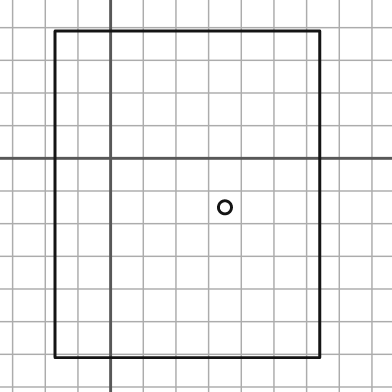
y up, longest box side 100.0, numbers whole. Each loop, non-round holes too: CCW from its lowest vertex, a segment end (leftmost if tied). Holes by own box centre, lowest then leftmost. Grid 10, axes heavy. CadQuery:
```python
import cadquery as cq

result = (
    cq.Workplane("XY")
    .moveTo(-17.0, -61.0)
    .lineTo(64.0, -61.0)
    .lineTo(64.0, 39.0)
    .lineTo(-17.0, 39.0)
    .close()
    .moveTo(35.0, -15.0)
    .circle(2.0)
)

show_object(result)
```